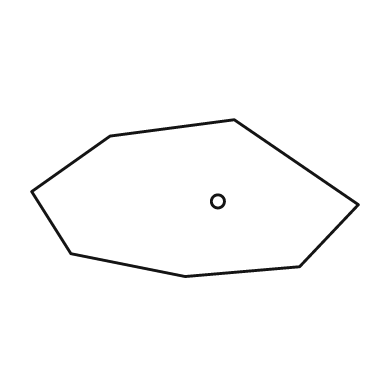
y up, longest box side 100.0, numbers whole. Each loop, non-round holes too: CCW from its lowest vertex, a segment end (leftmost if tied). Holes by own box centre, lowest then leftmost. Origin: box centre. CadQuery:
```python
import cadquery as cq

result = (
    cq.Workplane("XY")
    .moveTo(-3.0, -24.0)
    .lineTo(32.0, -21.0)
    .lineTo(50.0, -2.0)
    .lineTo(12.0, 24.0)
    .lineTo(-26.0, 19.0)
    .lineTo(-50.0, 2.0)
    .lineTo(-38.0, -17.0)
    .close()
    .moveTo(7.0, -1.0)
    .circle(2.0)
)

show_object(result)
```